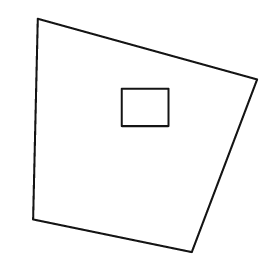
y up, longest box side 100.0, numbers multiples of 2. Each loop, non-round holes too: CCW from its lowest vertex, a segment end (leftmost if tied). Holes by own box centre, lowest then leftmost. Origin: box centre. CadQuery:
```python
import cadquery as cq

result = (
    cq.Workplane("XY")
    .moveTo(20.0, -50.0)
    .lineTo(48.0, 24.0)
    .lineTo(-46.0, 50.0)
    .lineTo(-48.0, -36.0)
    .close()
    .moveTo(-10.0, 4.0)
    .lineTo(10.0, 4.0)
    .lineTo(10.0, 20.0)
    .lineTo(-10.0, 20.0)
    .close()
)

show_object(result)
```